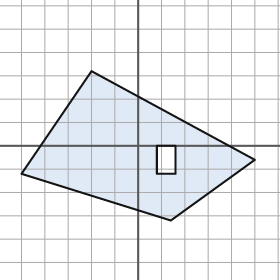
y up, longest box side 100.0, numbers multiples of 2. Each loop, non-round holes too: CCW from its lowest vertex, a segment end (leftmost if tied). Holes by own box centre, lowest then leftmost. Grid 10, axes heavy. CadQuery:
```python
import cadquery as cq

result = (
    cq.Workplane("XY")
    .moveTo(14.0, -32.0)
    .lineTo(50.0, -6.0)
    .lineTo(-20.0, 32.0)
    .lineTo(-50.0, -12.0)
    .close()
    .moveTo(8.0, -12.0)
    .lineTo(16.0, -12.0)
    .lineTo(16.0, 0.0)
    .lineTo(8.0, 0.0)
    .close()
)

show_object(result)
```